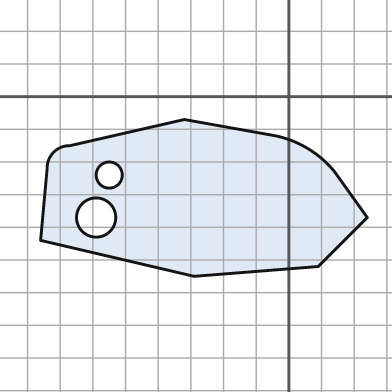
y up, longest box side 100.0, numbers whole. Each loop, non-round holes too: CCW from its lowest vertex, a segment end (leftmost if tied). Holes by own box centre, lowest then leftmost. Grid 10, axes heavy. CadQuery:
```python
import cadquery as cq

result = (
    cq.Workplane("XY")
    .moveTo(-29.0, -55.0)
    .lineTo(9.0, -52.0)
    .lineTo(24.0, -37.0)
    .lineTo(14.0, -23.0)
    .threePointArc((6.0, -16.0), (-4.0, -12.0))
    .lineTo(-32.0, -7.0)
    .lineTo(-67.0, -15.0)
    .threePointArc((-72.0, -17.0), (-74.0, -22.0))
    .lineTo(-76.0, -44.0)
    .close()
    .moveTo(-59.0, -37.0)
    .circle(6.0)
    .moveTo(-55.0, -24.0)
    .circle(4.0)
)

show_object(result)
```